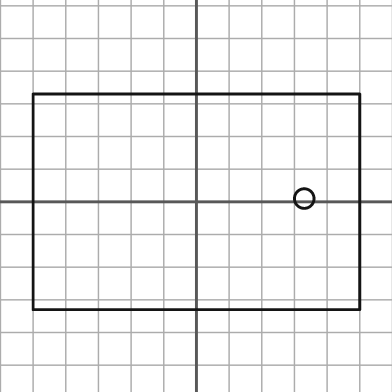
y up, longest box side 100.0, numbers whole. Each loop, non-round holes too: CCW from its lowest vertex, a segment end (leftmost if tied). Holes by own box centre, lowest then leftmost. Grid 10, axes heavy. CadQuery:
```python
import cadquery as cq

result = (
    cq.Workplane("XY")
    .moveTo(-50.0, -33.0)
    .lineTo(50.0, -33.0)
    .lineTo(50.0, 33.0)
    .lineTo(-50.0, 33.0)
    .close()
    .moveTo(33.0, 1.0)
    .circle(3.0)
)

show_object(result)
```